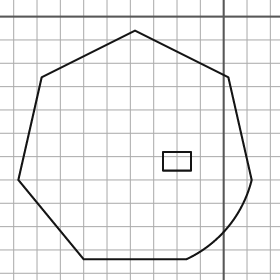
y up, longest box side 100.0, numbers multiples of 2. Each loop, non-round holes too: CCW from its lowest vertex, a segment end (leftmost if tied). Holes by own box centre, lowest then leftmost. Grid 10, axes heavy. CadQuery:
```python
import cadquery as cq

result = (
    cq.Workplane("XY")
    .moveTo(-60.0, -104.0)
    .lineTo(-16.0, -104.0)
    .threePointArc((2.0, -90.0), (12.0, -70.0))
    .lineTo(2.0, -26.0)
    .lineTo(-38.0, -6.0)
    .lineTo(-78.0, -26.0)
    .lineTo(-88.0, -70.0)
    .close()
    .moveTo(-26.0, -66.0)
    .lineTo(-14.0, -66.0)
    .lineTo(-14.0, -58.0)
    .lineTo(-26.0, -58.0)
    .close()
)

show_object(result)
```